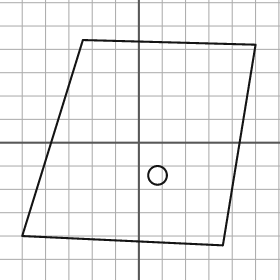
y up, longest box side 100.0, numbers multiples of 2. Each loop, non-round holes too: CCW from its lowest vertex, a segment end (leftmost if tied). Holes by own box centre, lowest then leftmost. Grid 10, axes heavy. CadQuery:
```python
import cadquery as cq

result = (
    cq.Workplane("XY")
    .moveTo(36.0, -44.0)
    .lineTo(50.0, 42.0)
    .lineTo(-24.0, 44.0)
    .lineTo(-50.0, -40.0)
    .close()
    .moveTo(8.0, -14.0)
    .circle(4.0)
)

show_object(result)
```